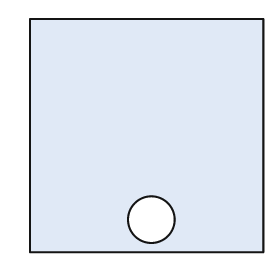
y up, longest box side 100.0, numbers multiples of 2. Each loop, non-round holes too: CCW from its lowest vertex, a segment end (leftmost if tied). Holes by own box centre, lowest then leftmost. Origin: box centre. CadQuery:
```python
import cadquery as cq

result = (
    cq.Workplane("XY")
    .moveTo(-50.0, -50.0)
    .lineTo(50.0, -50.0)
    .lineTo(50.0, 50.0)
    .lineTo(-50.0, 50.0)
    .close()
    .moveTo(2.0, -36.0)
    .circle(10.0)
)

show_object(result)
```